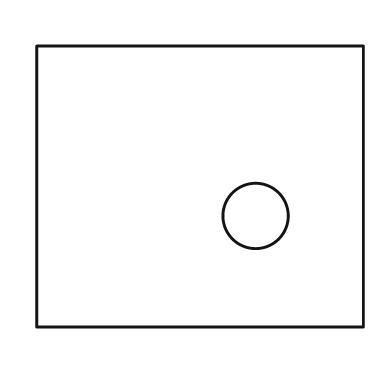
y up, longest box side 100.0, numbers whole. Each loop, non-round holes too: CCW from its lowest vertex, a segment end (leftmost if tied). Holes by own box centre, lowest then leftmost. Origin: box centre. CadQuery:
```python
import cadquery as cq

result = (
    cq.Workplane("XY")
    .moveTo(-50.0, -43.0)
    .lineTo(50.0, -43.0)
    .lineTo(50.0, 43.0)
    .lineTo(-50.0, 43.0)
    .close()
    .moveTo(17.0, -9.0)
    .circle(10.0)
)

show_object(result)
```